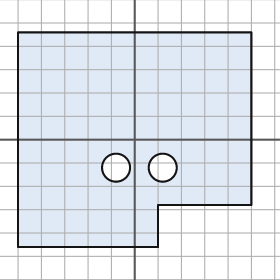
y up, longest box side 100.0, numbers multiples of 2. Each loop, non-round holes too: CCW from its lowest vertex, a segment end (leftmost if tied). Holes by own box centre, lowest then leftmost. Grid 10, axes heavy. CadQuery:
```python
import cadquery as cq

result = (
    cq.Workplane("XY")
    .moveTo(-50.0, -46.0)
    .lineTo(10.0, -46.0)
    .lineTo(10.0, -28.0)
    .lineTo(50.0, -28.0)
    .lineTo(50.0, 46.0)
    .lineTo(-50.0, 46.0)
    .close()
    .moveTo(-8.0, -12.0)
    .circle(6.0)
    .moveTo(12.0, -12.0)
    .circle(6.0)
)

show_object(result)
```